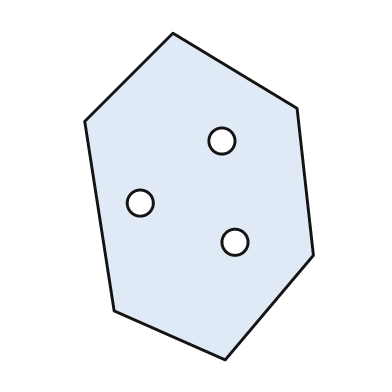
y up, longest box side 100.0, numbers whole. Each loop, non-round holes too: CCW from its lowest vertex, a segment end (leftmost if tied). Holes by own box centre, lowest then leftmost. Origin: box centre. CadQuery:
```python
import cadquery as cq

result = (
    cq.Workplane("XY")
    .moveTo(8.0, -50.0)
    .lineTo(35.0, -18.0)
    .lineTo(30.0, 27.0)
    .lineTo(-8.0, 50.0)
    .lineTo(-35.0, 23.0)
    .lineTo(-26.0, -35.0)
    .close()
    .moveTo(11.0, -14.0)
    .circle(4.0)
    .moveTo(-18.0, -2.0)
    .circle(4.0)
    .moveTo(7.0, 17.0)
    .circle(4.0)
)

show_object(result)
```